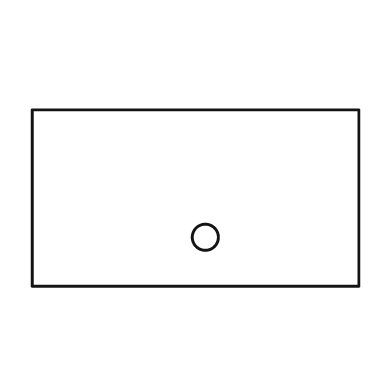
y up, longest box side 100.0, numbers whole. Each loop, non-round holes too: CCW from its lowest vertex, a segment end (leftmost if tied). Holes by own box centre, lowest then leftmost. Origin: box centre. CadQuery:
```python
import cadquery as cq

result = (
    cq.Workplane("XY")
    .moveTo(-50.0, -27.0)
    .lineTo(50.0, -27.0)
    .lineTo(50.0, 27.0)
    .lineTo(-50.0, 27.0)
    .close()
    .moveTo(3.0, -12.0)
    .circle(4.0)
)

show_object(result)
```